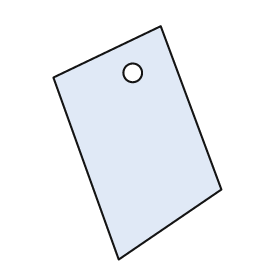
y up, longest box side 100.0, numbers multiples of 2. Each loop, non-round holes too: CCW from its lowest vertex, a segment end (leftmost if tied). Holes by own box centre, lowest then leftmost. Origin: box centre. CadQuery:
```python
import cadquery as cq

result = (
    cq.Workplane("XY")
    .moveTo(-8.0, -50.0)
    .lineTo(36.0, -20.0)
    .lineTo(10.0, 50.0)
    .lineTo(-36.0, 28.0)
    .close()
    .moveTo(-2.0, 30.0)
    .circle(4.0)
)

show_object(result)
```